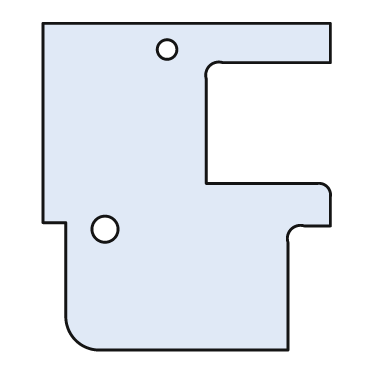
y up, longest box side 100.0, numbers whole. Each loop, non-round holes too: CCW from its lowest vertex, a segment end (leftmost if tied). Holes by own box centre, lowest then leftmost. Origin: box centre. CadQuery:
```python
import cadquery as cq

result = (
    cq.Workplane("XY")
    .moveTo(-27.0, -50.0)
    .lineTo(31.0, -50.0)
    .lineTo(31.0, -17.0)
    .threePointArc((32.0, -13.0), (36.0, -12.0))
    .lineTo(44.0, -12.0)
    .lineTo(44.0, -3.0)
    .threePointArc((43.0, 0.0), (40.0, 1.0))
    .lineTo(6.0, 1.0)
    .lineTo(6.0, 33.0)
    .threePointArc((7.0, 37.0), (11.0, 38.0))
    .lineTo(44.0, 38.0)
    .lineTo(44.0, 50.0)
    .lineTo(-44.0, 50.0)
    .lineTo(-44.0, -11.0)
    .lineTo(-37.0, -11.0)
    .lineTo(-37.0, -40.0)
    .threePointArc((-34.0, -47.0), (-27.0, -50.0))
    .close()
    .moveTo(-25.0, -13.0)
    .circle(4.0)
    .moveTo(-6.0, 42.0)
    .circle(3.0)
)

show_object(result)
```